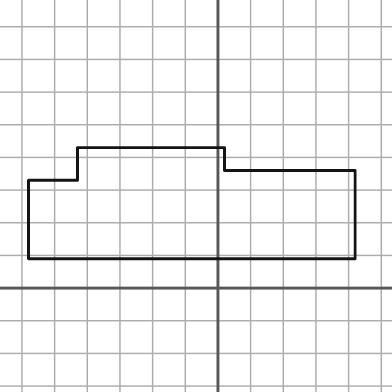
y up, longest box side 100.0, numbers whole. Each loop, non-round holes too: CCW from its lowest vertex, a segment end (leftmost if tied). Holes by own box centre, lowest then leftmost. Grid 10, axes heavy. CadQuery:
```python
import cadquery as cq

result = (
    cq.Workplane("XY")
    .moveTo(-58.0, 9.0)
    .lineTo(42.0, 9.0)
    .lineTo(42.0, 36.0)
    .lineTo(2.0, 36.0)
    .lineTo(2.0, 43.0)
    .lineTo(-43.0, 43.0)
    .lineTo(-43.0, 33.0)
    .lineTo(-58.0, 33.0)
    .close()
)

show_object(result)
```